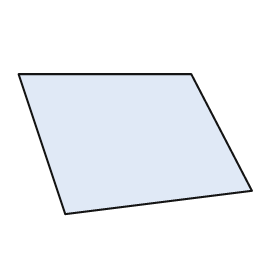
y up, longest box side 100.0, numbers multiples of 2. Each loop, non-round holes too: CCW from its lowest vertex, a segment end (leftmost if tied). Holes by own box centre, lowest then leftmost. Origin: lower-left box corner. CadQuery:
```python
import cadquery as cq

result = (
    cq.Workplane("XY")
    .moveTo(20.0, 0.0)
    .lineTo(100.0, 10.0)
    .lineTo(74.0, 60.0)
    .lineTo(0.0, 60.0)
    .close()
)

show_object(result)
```